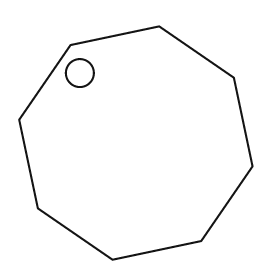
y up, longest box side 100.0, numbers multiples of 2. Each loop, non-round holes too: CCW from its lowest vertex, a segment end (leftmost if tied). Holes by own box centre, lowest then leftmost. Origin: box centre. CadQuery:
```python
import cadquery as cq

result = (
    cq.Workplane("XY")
    .moveTo(-10.0, -50.0)
    .lineTo(28.0, -42.0)
    .lineTo(50.0, -10.0)
    .lineTo(42.0, 28.0)
    .lineTo(10.0, 50.0)
    .lineTo(-28.0, 42.0)
    .lineTo(-50.0, 10.0)
    .lineTo(-42.0, -28.0)
    .close()
    .moveTo(-24.0, 30.0)
    .circle(6.0)
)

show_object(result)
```